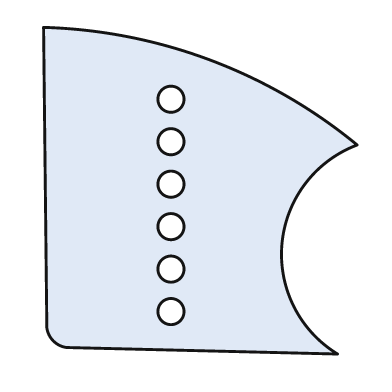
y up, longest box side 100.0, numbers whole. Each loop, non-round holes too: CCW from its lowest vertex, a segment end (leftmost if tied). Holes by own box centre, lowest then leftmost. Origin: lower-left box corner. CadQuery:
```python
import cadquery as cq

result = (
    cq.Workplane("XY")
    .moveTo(90.0, 0.0)
    .threePointArc((73.0, 34.0), (96.0, 64.0))
    .threePointArc((51.0, 90.0), (0.0, 100.0))
    .lineTo(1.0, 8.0)
    .threePointArc((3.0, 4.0), (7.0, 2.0))
    .close()
    .moveTo(39.0, 13.0)
    .circle(4.0)
    .moveTo(39.0, 26.0)
    .circle(4.0)
    .moveTo(39.0, 39.0)
    .circle(4.0)
    .moveTo(39.0, 52.0)
    .circle(4.0)
    .moveTo(39.0, 65.0)
    .circle(4.0)
    .moveTo(39.0, 78.0)
    .circle(4.0)
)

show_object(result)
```